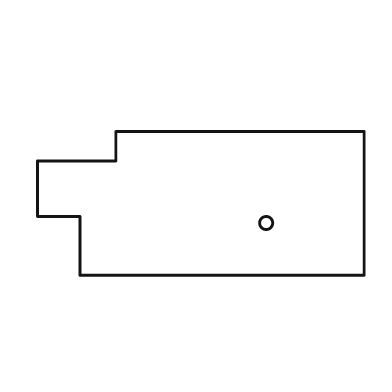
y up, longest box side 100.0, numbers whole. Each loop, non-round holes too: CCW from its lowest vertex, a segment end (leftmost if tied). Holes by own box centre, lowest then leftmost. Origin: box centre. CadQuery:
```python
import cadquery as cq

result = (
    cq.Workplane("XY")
    .moveTo(-37.0, -22.0)
    .lineTo(50.0, -22.0)
    .lineTo(50.0, 22.0)
    .lineTo(-26.0, 22.0)
    .lineTo(-26.0, 13.0)
    .lineTo(-50.0, 13.0)
    .lineTo(-50.0, -4.0)
    .lineTo(-37.0, -4.0)
    .close()
    .moveTo(20.0, -6.0)
    .circle(2.0)
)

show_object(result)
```